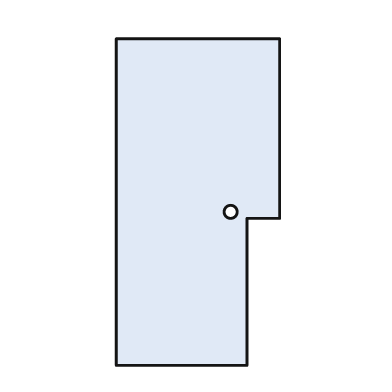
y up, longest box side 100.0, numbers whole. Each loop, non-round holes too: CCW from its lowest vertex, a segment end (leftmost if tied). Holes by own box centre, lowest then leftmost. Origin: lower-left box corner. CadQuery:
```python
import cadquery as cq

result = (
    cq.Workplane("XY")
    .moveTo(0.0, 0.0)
    .lineTo(40.0, 0.0)
    .lineTo(40.0, 45.0)
    .lineTo(50.0, 45.0)
    .lineTo(50.0, 100.0)
    .lineTo(0.0, 100.0)
    .close()
    .moveTo(35.0, 47.0)
    .circle(2.0)
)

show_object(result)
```